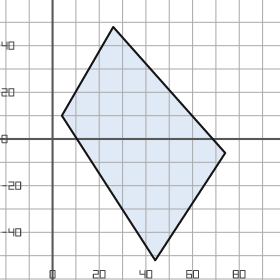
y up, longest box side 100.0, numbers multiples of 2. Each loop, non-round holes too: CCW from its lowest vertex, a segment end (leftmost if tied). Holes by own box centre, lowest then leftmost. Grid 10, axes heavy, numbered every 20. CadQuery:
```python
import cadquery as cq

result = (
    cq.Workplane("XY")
    .moveTo(44.0, -52.0)
    .lineTo(74.0, -6.0)
    .lineTo(26.0, 48.0)
    .lineTo(4.0, 10.0)
    .close()
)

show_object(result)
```